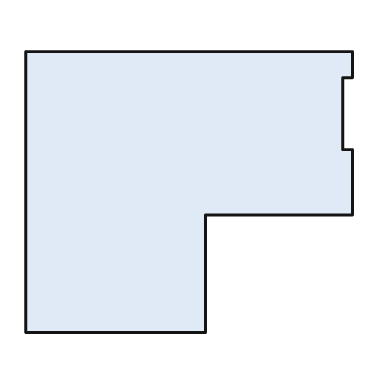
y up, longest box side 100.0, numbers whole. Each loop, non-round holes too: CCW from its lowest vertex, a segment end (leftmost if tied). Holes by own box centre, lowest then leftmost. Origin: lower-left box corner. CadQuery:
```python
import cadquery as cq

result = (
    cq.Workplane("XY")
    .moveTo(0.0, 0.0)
    .lineTo(55.0, 0.0)
    .lineTo(55.0, 36.0)
    .lineTo(100.0, 36.0)
    .lineTo(100.0, 56.0)
    .lineTo(97.0, 56.0)
    .lineTo(97.0, 78.0)
    .lineTo(100.0, 78.0)
    .lineTo(100.0, 86.0)
    .lineTo(0.0, 86.0)
    .close()
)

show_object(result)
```